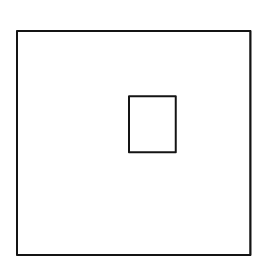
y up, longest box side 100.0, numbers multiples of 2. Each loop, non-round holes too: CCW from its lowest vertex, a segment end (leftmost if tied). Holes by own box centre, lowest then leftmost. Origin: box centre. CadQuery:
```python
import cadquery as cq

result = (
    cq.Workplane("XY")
    .moveTo(-50.0, -48.0)
    .lineTo(50.0, -48.0)
    .lineTo(50.0, 48.0)
    .lineTo(-50.0, 48.0)
    .close()
    .moveTo(-2.0, -4.0)
    .lineTo(18.0, -4.0)
    .lineTo(18.0, 20.0)
    .lineTo(-2.0, 20.0)
    .close()
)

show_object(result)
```